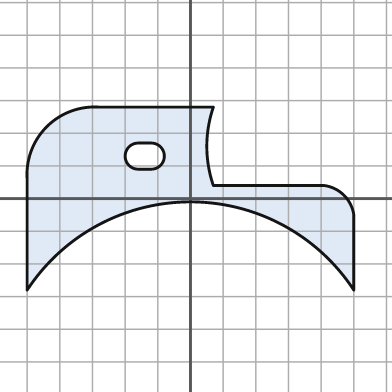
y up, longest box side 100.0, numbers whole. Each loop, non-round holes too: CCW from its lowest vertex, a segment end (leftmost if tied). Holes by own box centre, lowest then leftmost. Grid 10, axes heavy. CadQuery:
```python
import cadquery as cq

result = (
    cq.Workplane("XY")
    .moveTo(-50.0, -28.0)
    .threePointArc((0.0, -1.0), (50.0, -28.0))
    .lineTo(50.0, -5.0)
    .threePointArc((47.0, 1.0), (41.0, 4.0))
    .lineTo(7.0, 4.0)
    .threePointArc((5.0, 16.0), (7.0, 28.0))
    .lineTo(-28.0, 28.0)
    .threePointArc((-44.0, 22.0), (-50.0, 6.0))
    .close()
    .moveTo(-16.0, 9.0)
    .lineTo(-12.0, 9.0)
    .threePointArc((-8.0, 13.0), (-12.0, 17.0))
    .lineTo(-16.0, 17.0)
    .threePointArc((-20.0, 13.0), (-16.0, 9.0))
    .close()
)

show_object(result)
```